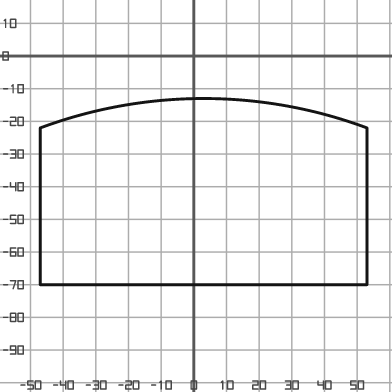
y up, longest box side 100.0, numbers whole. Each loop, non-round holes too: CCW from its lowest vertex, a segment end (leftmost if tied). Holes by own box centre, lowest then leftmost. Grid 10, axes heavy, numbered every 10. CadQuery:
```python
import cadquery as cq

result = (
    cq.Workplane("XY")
    .moveTo(-47.0, -70.0)
    .lineTo(53.0, -70.0)
    .lineTo(53.0, -22.0)
    .threePointArc((3.0, -13.0), (-47.0, -22.0))
    .close()
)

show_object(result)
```